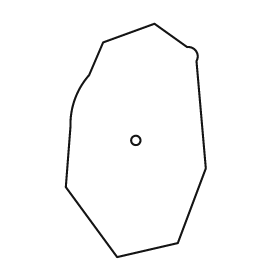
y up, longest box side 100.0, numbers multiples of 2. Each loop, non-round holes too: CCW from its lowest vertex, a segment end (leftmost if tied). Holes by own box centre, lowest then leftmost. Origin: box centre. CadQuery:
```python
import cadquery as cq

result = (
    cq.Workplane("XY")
    .moveTo(-8.0, -50.0)
    .lineTo(18.0, -44.0)
    .lineTo(30.0, -12.0)
    .lineTo(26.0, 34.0)
    .threePointArc((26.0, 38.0), (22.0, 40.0))
    .lineTo(8.0, 50.0)
    .lineTo(-14.0, 42.0)
    .lineTo(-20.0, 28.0)
    .threePointArc((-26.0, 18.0), (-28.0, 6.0))
    .lineTo(-30.0, -20.0)
    .close()
    .moveTo(0.0, 0.0)
    .circle(2.0)
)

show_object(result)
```